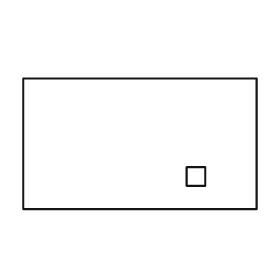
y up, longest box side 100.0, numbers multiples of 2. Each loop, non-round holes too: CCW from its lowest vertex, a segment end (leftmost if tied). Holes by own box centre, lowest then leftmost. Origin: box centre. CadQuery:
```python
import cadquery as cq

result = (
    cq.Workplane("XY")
    .moveTo(-50.0, -28.0)
    .lineTo(50.0, -28.0)
    .lineTo(50.0, 28.0)
    .lineTo(-50.0, 28.0)
    .close()
    .moveTo(20.0, -18.0)
    .lineTo(28.0, -18.0)
    .lineTo(28.0, -10.0)
    .lineTo(20.0, -10.0)
    .close()
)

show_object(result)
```